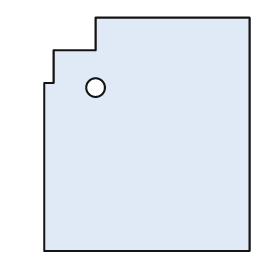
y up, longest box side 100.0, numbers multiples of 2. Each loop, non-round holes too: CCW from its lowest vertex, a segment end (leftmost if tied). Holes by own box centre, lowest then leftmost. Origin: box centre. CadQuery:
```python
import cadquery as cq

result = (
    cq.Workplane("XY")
    .moveTo(-44.0, -50.0)
    .lineTo(44.0, -50.0)
    .lineTo(44.0, 50.0)
    .lineTo(-22.0, 50.0)
    .lineTo(-22.0, 36.0)
    .lineTo(-40.0, 36.0)
    .lineTo(-40.0, 22.0)
    .lineTo(-44.0, 22.0)
    .close()
    .moveTo(-22.0, 20.0)
    .circle(4.0)
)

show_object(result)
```